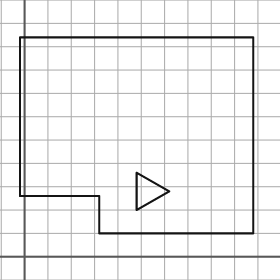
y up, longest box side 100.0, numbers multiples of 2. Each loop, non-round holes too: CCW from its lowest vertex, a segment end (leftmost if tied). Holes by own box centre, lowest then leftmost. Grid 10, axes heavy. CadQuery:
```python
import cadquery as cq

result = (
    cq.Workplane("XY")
    .moveTo(32.0, 10.0)
    .lineTo(98.0, 10.0)
    .lineTo(98.0, 94.0)
    .lineTo(-2.0, 94.0)
    .lineTo(-2.0, 26.0)
    .lineTo(32.0, 26.0)
    .close()
    .moveTo(48.0, 20.0)
    .lineTo(62.0, 28.0)
    .lineTo(48.0, 36.0)
    .close()
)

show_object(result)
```